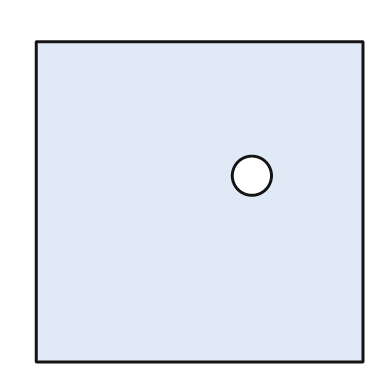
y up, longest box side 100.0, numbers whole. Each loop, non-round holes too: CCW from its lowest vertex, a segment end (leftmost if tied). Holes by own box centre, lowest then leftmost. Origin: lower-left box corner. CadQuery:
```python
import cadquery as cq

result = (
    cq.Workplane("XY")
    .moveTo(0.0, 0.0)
    .lineTo(100.0, 0.0)
    .lineTo(100.0, 98.0)
    .lineTo(0.0, 98.0)
    .close()
    .moveTo(66.0, 57.0)
    .circle(6.0)
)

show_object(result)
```